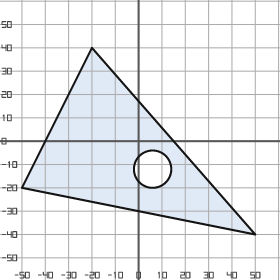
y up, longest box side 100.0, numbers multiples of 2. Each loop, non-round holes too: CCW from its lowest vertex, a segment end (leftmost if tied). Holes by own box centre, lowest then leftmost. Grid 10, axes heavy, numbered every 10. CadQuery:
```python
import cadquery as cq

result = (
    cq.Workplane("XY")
    .moveTo(50.0, -40.0)
    .lineTo(-20.0, 40.0)
    .lineTo(-50.0, -20.0)
    .close()
    .moveTo(6.0, -12.0)
    .circle(8.0)
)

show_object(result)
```